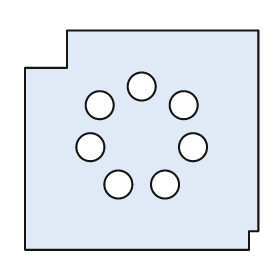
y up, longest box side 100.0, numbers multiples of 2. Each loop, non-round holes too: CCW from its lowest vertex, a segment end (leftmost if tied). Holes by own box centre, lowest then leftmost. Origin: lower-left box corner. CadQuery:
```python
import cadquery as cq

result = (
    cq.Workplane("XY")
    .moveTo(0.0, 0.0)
    .lineTo(96.0, 0.0)
    .lineTo(96.0, 8.0)
    .lineTo(100.0, 8.0)
    .lineTo(100.0, 94.0)
    .lineTo(18.0, 94.0)
    .lineTo(18.0, 78.0)
    .lineTo(0.0, 78.0)
    .close()
    .moveTo(40.0, 28.0)
    .circle(6.0)
    .moveTo(60.0, 28.0)
    .circle(6.0)
    .moveTo(28.0, 44.0)
    .circle(6.0)
    .moveTo(72.0, 44.0)
    .circle(6.0)
    .moveTo(32.0, 62.0)
    .circle(6.0)
    .moveTo(68.0, 62.0)
    .circle(6.0)
    .moveTo(50.0, 70.0)
    .circle(6.0)
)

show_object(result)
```